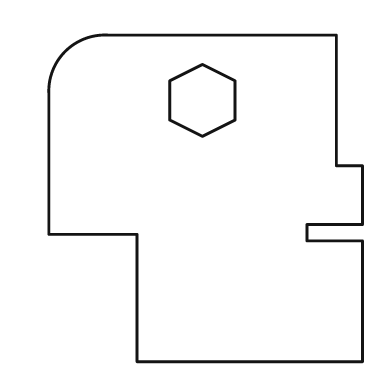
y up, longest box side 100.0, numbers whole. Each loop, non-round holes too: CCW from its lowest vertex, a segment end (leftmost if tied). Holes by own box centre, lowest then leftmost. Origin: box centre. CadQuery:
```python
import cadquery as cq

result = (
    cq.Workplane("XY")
    .moveTo(-21.0, -50.0)
    .lineTo(48.0, -50.0)
    .lineTo(48.0, -13.0)
    .lineTo(31.0, -13.0)
    .lineTo(31.0, -8.0)
    .lineTo(48.0, -8.0)
    .lineTo(48.0, 10.0)
    .lineTo(40.0, 10.0)
    .lineTo(40.0, 50.0)
    .lineTo(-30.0, 50.0)
    .threePointArc((-43.0, 45.0), (-48.0, 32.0))
    .lineTo(-48.0, -11.0)
    .lineTo(-21.0, -11.0)
    .close()
    .moveTo(-1.0, 19.0)
    .lineTo(9.0, 24.0)
    .lineTo(9.0, 36.0)
    .lineTo(-1.0, 41.0)
    .lineTo(-11.0, 36.0)
    .lineTo(-11.0, 24.0)
    .close()
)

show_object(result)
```